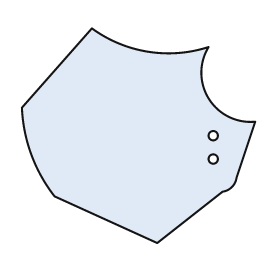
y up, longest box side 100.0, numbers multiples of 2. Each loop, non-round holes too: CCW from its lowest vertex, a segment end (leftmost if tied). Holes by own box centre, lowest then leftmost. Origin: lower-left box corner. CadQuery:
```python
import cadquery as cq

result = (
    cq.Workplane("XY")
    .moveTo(58.0, 0.0)
    .lineTo(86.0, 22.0)
    .threePointArc((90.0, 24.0), (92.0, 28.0))
    .lineTo(100.0, 52.0)
    .threePointArc((80.0, 62.0), (80.0, 84.0))
    .threePointArc((54.0, 82.0), (30.0, 92.0))
    .lineTo(0.0, 58.0)
    .threePointArc((4.0, 38.0), (14.0, 20.0))
    .close()
    .moveTo(82.0, 36.0)
    .circle(2.0)
    .moveTo(82.0, 46.0)
    .circle(2.0)
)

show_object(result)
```